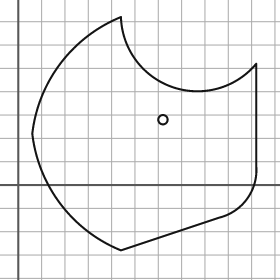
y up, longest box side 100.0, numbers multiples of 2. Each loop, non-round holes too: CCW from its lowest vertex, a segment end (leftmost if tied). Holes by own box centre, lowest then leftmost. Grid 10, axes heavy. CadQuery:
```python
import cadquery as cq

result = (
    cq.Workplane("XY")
    .moveTo(44.0, -28.0)
    .lineTo(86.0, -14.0)
    .threePointArc((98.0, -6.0), (102.0, 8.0))
    .lineTo(102.0, 52.0)
    .threePointArc((66.0, 42.0), (44.0, 72.0))
    .threePointArc((18.0, 52.0), (6.0, 22.0))
    .threePointArc((18.0, -8.0), (44.0, -28.0))
    .close()
    .moveTo(62.0, 28.0)
    .circle(2.0)
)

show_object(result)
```